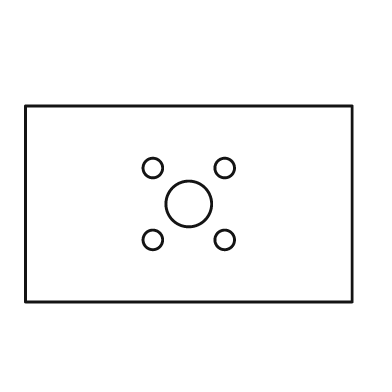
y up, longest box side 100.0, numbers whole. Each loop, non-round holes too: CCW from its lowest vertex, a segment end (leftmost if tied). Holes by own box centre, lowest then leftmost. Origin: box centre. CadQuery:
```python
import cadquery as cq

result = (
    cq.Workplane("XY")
    .moveTo(-50.0, -30.0)
    .lineTo(50.0, -30.0)
    .lineTo(50.0, 30.0)
    .lineTo(-50.0, 30.0)
    .close()
    .moveTo(-11.0, -11.0)
    .circle(3.0)
    .moveTo(11.0, -11.0)
    .circle(3.0)
    .moveTo(0.0, 0.0)
    .circle(7.0)
    .moveTo(-11.0, 11.0)
    .circle(3.0)
    .moveTo(11.0, 11.0)
    .circle(3.0)
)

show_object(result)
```